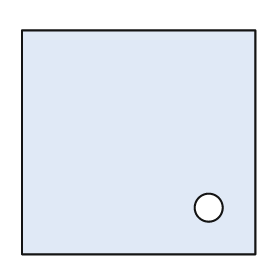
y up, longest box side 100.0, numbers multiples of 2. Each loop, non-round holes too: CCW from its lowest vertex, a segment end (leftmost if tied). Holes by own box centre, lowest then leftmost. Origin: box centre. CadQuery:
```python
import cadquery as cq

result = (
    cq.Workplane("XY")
    .moveTo(-50.0, -48.0)
    .lineTo(50.0, -48.0)
    .lineTo(50.0, 48.0)
    .lineTo(-50.0, 48.0)
    .close()
    .moveTo(30.0, -28.0)
    .circle(6.0)
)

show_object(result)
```